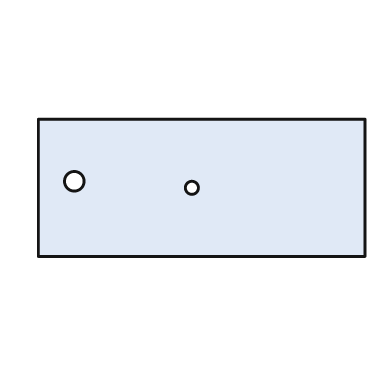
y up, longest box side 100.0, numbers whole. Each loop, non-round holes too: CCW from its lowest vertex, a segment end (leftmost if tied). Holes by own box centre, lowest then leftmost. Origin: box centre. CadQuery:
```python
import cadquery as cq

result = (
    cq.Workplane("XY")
    .moveTo(-50.0, -21.0)
    .lineTo(50.0, -21.0)
    .lineTo(50.0, 21.0)
    .lineTo(-50.0, 21.0)
    .close()
    .moveTo(-3.0, 0.0)
    .circle(2.0)
    .moveTo(-39.0, 2.0)
    .circle(3.0)
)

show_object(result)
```